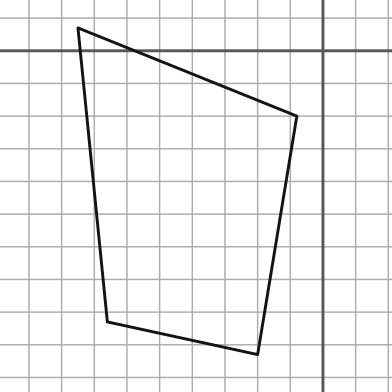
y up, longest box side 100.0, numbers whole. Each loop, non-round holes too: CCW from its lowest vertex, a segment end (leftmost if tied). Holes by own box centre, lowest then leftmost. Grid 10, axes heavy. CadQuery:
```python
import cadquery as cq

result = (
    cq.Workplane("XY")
    .moveTo(-20.0, -93.0)
    .lineTo(-8.0, -20.0)
    .lineTo(-75.0, 7.0)
    .lineTo(-66.0, -83.0)
    .close()
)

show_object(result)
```